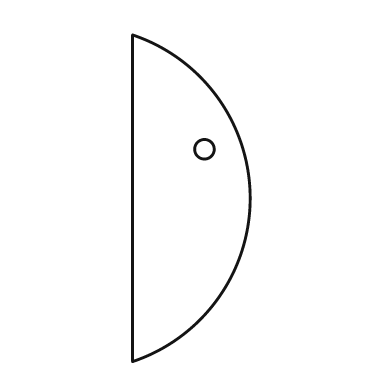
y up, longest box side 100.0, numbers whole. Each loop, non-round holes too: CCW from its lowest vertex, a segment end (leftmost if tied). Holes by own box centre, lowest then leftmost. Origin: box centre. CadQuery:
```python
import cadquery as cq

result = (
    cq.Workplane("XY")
    .moveTo(-18.0, -50.0)
    .threePointArc((18.0, 0.0), (-18.0, 50.0))
    .close()
    .moveTo(4.0, 15.0)
    .circle(3.0)
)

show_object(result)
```